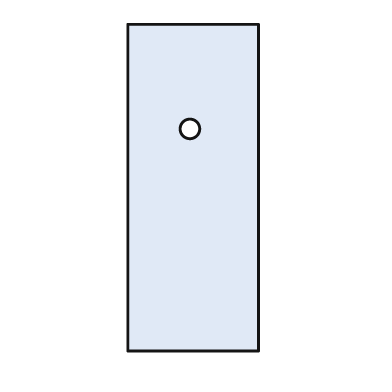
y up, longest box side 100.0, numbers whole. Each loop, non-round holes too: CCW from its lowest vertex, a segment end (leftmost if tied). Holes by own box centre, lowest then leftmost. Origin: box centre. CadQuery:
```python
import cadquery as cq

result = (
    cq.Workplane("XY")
    .moveTo(-20.0, -50.0)
    .lineTo(20.0, -50.0)
    .lineTo(20.0, 50.0)
    .lineTo(-20.0, 50.0)
    .close()
    .moveTo(-1.0, 18.0)
    .circle(3.0)
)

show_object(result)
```